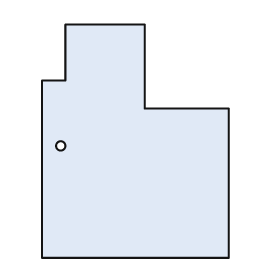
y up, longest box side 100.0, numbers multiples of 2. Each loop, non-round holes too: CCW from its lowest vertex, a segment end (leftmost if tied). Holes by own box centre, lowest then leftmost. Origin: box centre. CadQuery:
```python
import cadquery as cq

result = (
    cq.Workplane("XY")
    .moveTo(-40.0, -50.0)
    .lineTo(40.0, -50.0)
    .lineTo(40.0, 14.0)
    .lineTo(4.0, 14.0)
    .lineTo(4.0, 50.0)
    .lineTo(-30.0, 50.0)
    .lineTo(-30.0, 26.0)
    .lineTo(-40.0, 26.0)
    .close()
    .moveTo(-32.0, -2.0)
    .circle(2.0)
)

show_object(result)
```